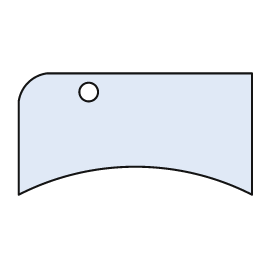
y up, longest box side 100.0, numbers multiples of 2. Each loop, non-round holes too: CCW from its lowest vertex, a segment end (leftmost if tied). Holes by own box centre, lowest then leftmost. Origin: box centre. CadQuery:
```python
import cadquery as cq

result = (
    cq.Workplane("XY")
    .moveTo(-50.0, -26.0)
    .threePointArc((0.0, -14.0), (50.0, -26.0))
    .lineTo(50.0, 26.0)
    .lineTo(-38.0, 26.0)
    .threePointArc((-46.0, 22.0), (-50.0, 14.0))
    .close()
    .moveTo(-20.0, 18.0)
    .circle(4.0)
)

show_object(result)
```